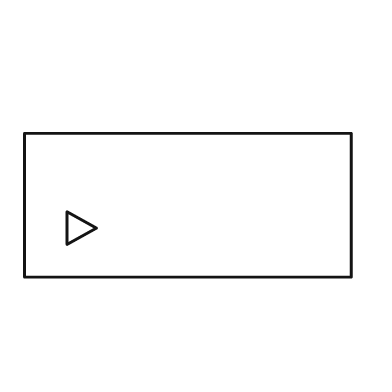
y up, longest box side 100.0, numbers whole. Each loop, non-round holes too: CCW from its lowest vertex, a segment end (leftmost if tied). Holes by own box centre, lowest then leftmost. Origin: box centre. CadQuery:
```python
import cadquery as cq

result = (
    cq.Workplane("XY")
    .moveTo(-50.0, -22.0)
    .lineTo(50.0, -22.0)
    .lineTo(50.0, 22.0)
    .lineTo(-50.0, 22.0)
    .close()
    .moveTo(-37.0, -12.0)
    .lineTo(-28.0, -7.0)
    .lineTo(-37.0, -2.0)
    .close()
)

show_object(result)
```